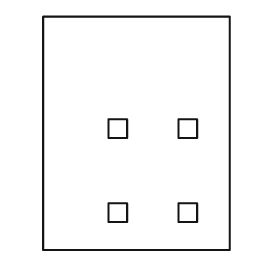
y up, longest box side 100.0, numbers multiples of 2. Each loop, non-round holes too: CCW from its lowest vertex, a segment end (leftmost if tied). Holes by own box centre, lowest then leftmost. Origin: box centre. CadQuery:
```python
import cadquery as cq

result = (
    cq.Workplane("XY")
    .moveTo(-40.0, -50.0)
    .lineTo(40.0, -50.0)
    .lineTo(40.0, 50.0)
    .lineTo(-40.0, 50.0)
    .close()
    .moveTo(-12.0, -38.0)
    .lineTo(-4.0, -38.0)
    .lineTo(-4.0, -30.0)
    .lineTo(-12.0, -30.0)
    .close()
    .moveTo(18.0, -38.0)
    .lineTo(26.0, -38.0)
    .lineTo(26.0, -30.0)
    .lineTo(18.0, -30.0)
    .close()
    .moveTo(-12.0, -2.0)
    .lineTo(-4.0, -2.0)
    .lineTo(-4.0, 6.0)
    .lineTo(-12.0, 6.0)
    .close()
    .moveTo(18.0, -2.0)
    .lineTo(26.0, -2.0)
    .lineTo(26.0, 6.0)
    .lineTo(18.0, 6.0)
    .close()
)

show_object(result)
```